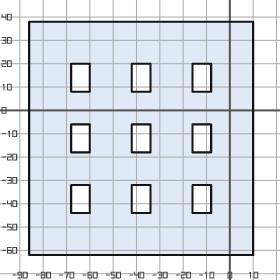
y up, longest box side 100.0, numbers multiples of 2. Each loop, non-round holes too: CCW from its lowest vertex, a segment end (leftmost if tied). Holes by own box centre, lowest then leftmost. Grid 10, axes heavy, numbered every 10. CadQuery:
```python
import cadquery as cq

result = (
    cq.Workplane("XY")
    .moveTo(-86.0, -62.0)
    .lineTo(10.0, -62.0)
    .lineTo(10.0, 38.0)
    .lineTo(-86.0, 38.0)
    .close()
    .moveTo(-68.0, -44.0)
    .lineTo(-60.0, -44.0)
    .lineTo(-60.0, -32.0)
    .lineTo(-68.0, -32.0)
    .close()
    .moveTo(-42.0, -44.0)
    .lineTo(-34.0, -44.0)
    .lineTo(-34.0, -32.0)
    .lineTo(-42.0, -32.0)
    .close()
    .moveTo(-16.0, -44.0)
    .lineTo(-8.0, -44.0)
    .lineTo(-8.0, -32.0)
    .lineTo(-16.0, -32.0)
    .close()
    .moveTo(-68.0, -18.0)
    .lineTo(-60.0, -18.0)
    .lineTo(-60.0, -6.0)
    .lineTo(-68.0, -6.0)
    .close()
    .moveTo(-42.0, -18.0)
    .lineTo(-34.0, -18.0)
    .lineTo(-34.0, -6.0)
    .lineTo(-42.0, -6.0)
    .close()
    .moveTo(-16.0, -18.0)
    .lineTo(-8.0, -18.0)
    .lineTo(-8.0, -6.0)
    .lineTo(-16.0, -6.0)
    .close()
    .moveTo(-68.0, 8.0)
    .lineTo(-60.0, 8.0)
    .lineTo(-60.0, 20.0)
    .lineTo(-68.0, 20.0)
    .close()
    .moveTo(-42.0, 8.0)
    .lineTo(-34.0, 8.0)
    .lineTo(-34.0, 20.0)
    .lineTo(-42.0, 20.0)
    .close()
    .moveTo(-16.0, 8.0)
    .lineTo(-8.0, 8.0)
    .lineTo(-8.0, 20.0)
    .lineTo(-16.0, 20.0)
    .close()
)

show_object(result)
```